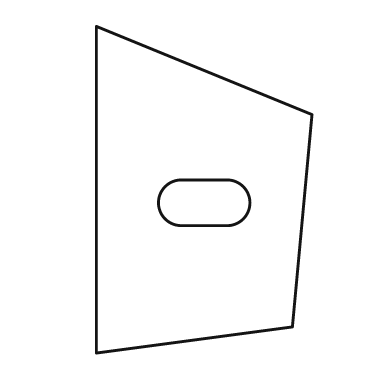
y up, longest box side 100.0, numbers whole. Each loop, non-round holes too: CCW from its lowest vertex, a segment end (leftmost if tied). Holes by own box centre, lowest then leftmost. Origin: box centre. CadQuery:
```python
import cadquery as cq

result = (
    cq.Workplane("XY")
    .moveTo(-33.0, -50.0)
    .lineTo(27.0, -42.0)
    .lineTo(33.0, 23.0)
    .lineTo(-33.0, 50.0)
    .close()
    .moveTo(-7.0, -11.0)
    .lineTo(7.0, -11.0)
    .threePointArc((14.0, -4.0), (7.0, 3.0))
    .lineTo(-7.0, 3.0)
    .threePointArc((-14.0, -4.0), (-7.0, -11.0))
    .close()
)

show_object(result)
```